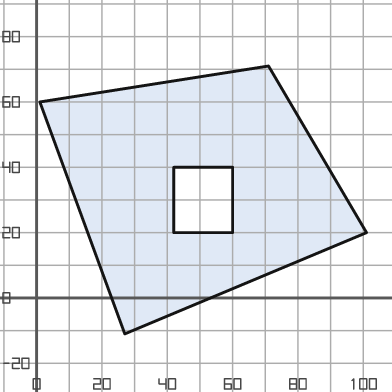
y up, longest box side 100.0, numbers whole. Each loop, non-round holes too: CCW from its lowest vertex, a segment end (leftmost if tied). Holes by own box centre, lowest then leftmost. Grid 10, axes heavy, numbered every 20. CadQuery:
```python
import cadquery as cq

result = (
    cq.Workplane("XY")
    .moveTo(27.0, -11.0)
    .lineTo(101.0, 20.0)
    .lineTo(71.0, 71.0)
    .lineTo(1.0, 60.0)
    .close()
    .moveTo(42.0, 20.0)
    .lineTo(60.0, 20.0)
    .lineTo(60.0, 40.0)
    .lineTo(42.0, 40.0)
    .close()
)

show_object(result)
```